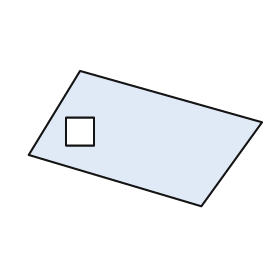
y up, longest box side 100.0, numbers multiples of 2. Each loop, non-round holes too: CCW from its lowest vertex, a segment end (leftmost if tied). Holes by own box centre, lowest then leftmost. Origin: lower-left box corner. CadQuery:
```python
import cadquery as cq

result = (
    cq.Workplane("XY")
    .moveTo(74.0, 0.0)
    .lineTo(100.0, 36.0)
    .lineTo(22.0, 58.0)
    .lineTo(0.0, 22.0)
    .close()
    .moveTo(16.0, 26.0)
    .lineTo(28.0, 26.0)
    .lineTo(28.0, 38.0)
    .lineTo(16.0, 38.0)
    .close()
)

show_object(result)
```